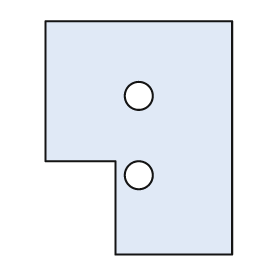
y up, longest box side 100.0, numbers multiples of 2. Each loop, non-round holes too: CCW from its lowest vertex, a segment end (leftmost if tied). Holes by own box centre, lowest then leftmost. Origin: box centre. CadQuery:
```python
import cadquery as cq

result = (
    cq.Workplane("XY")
    .moveTo(-10.0, -50.0)
    .lineTo(40.0, -50.0)
    .lineTo(40.0, 50.0)
    .lineTo(-40.0, 50.0)
    .lineTo(-40.0, -10.0)
    .lineTo(-10.0, -10.0)
    .close()
    .moveTo(0.0, -16.0)
    .circle(6.0)
    .moveTo(0.0, 18.0)
    .circle(6.0)
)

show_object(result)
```